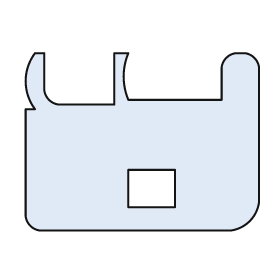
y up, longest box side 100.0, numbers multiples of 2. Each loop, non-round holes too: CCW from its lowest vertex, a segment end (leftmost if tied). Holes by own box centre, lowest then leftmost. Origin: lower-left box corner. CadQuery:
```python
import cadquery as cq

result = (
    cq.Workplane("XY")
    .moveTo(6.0, 0.0)
    .lineTo(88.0, 0.0)
    .threePointArc((96.0, 4.0), (100.0, 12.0))
    .lineTo(100.0, 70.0)
    .threePointArc((98.0, 74.0), (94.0, 76.0))
    .lineTo(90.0, 76.0)
    .threePointArc((86.0, 74.0), (84.0, 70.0))
    .lineTo(84.0, 56.0)
    .lineTo(44.0, 56.0)
    .threePointArc((42.0, 66.0), (44.0, 76.0))
    .lineTo(38.0, 76.0)
    .lineTo(38.0, 54.0)
    .lineTo(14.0, 54.0)
    .threePointArc((10.0, 56.0), (8.0, 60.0))
    .lineTo(8.0, 76.0)
    .lineTo(4.0, 76.0)
    .threePointArc((0.0, 64.0), (4.0, 52.0))
    .lineTo(0.0, 52.0)
    .lineTo(0.0, 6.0)
    .threePointArc((2.0, 2.0), (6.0, 0.0))
    .close()
    .moveTo(44.0, 10.0)
    .lineTo(64.0, 10.0)
    .lineTo(64.0, 26.0)
    .lineTo(44.0, 26.0)
    .close()
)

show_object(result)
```